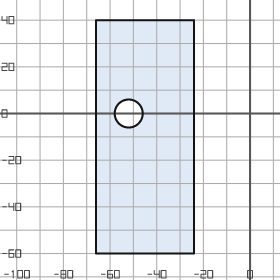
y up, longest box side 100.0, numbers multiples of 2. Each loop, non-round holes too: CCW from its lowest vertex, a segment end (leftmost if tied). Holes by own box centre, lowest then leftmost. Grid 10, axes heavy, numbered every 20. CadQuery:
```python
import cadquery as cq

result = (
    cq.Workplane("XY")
    .moveTo(-66.0, -60.0)
    .lineTo(-24.0, -60.0)
    .lineTo(-24.0, 40.0)
    .lineTo(-66.0, 40.0)
    .close()
    .moveTo(-52.0, 0.0)
    .circle(6.0)
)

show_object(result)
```